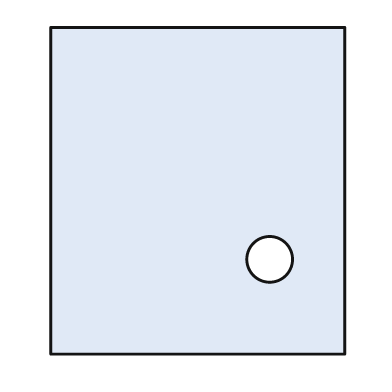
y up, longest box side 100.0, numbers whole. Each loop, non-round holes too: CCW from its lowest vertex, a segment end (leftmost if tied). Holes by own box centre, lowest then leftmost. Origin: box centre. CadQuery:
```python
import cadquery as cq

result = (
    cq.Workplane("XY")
    .moveTo(-45.0, -50.0)
    .lineTo(45.0, -50.0)
    .lineTo(45.0, 50.0)
    .lineTo(-45.0, 50.0)
    .close()
    .moveTo(22.0, -21.0)
    .circle(7.0)
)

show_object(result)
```